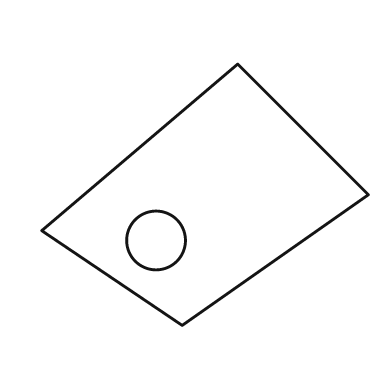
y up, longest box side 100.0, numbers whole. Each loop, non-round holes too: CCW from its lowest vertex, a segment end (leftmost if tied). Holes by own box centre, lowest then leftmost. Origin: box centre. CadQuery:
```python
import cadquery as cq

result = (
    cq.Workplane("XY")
    .moveTo(-7.0, -40.0)
    .lineTo(50.0, 0.0)
    .lineTo(10.0, 40.0)
    .lineTo(-50.0, -11.0)
    .close()
    .moveTo(-15.0, -14.0)
    .circle(9.0)
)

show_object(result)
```